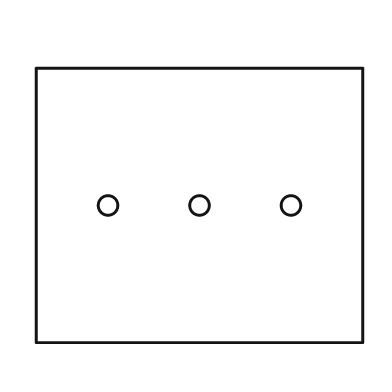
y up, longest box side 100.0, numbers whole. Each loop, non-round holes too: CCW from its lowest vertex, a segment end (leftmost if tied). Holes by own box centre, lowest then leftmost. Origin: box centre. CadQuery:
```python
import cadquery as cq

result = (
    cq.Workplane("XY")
    .moveTo(-50.0, -42.0)
    .lineTo(50.0, -42.0)
    .lineTo(50.0, 42.0)
    .lineTo(-50.0, 42.0)
    .close()
    .moveTo(-28.0, 0.0)
    .circle(3.0)
    .moveTo(0.0, 0.0)
    .circle(3.0)
    .moveTo(28.0, 0.0)
    .circle(3.0)
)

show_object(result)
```